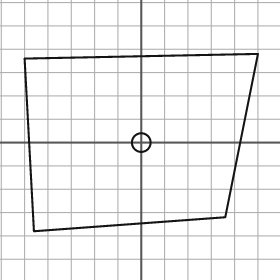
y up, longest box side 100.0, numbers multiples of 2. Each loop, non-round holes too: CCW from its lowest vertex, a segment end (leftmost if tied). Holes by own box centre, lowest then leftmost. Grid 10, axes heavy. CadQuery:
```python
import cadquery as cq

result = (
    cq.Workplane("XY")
    .moveTo(-46.0, -38.0)
    .lineTo(36.0, -32.0)
    .lineTo(50.0, 38.0)
    .lineTo(-50.0, 36.0)
    .close()
    .moveTo(0.0, 0.0)
    .circle(4.0)
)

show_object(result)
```